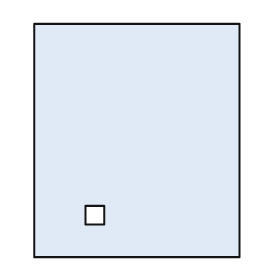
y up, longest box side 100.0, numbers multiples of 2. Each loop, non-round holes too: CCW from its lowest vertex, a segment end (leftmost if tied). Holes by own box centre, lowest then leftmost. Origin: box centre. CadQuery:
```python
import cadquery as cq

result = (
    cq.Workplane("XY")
    .moveTo(-44.0, -50.0)
    .lineTo(44.0, -50.0)
    .lineTo(44.0, 50.0)
    .lineTo(-44.0, 50.0)
    .close()
    .moveTo(-22.0, -36.0)
    .lineTo(-14.0, -36.0)
    .lineTo(-14.0, -28.0)
    .lineTo(-22.0, -28.0)
    .close()
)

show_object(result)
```